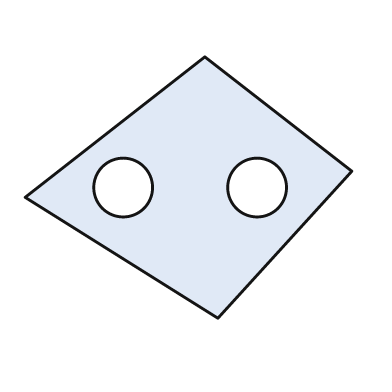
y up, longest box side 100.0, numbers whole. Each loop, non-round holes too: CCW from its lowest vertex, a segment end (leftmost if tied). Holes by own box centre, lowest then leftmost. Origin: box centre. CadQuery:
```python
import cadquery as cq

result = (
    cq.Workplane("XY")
    .moveTo(9.0, -40.0)
    .lineTo(50.0, 5.0)
    .lineTo(5.0, 40.0)
    .lineTo(-50.0, -3.0)
    .close()
    .moveTo(-20.0, 0.0)
    .circle(9.0)
    .moveTo(21.0, 0.0)
    .circle(9.0)
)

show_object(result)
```